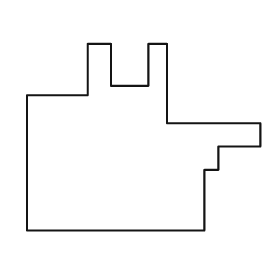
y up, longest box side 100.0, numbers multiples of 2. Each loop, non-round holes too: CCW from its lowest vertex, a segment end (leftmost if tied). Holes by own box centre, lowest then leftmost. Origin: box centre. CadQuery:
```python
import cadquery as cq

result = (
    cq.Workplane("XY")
    .moveTo(-50.0, -40.0)
    .lineTo(26.0, -40.0)
    .lineTo(26.0, -14.0)
    .lineTo(32.0, -14.0)
    .lineTo(32.0, -4.0)
    .lineTo(50.0, -4.0)
    .lineTo(50.0, 6.0)
    .lineTo(10.0, 6.0)
    .lineTo(10.0, 40.0)
    .lineTo(2.0, 40.0)
    .lineTo(2.0, 22.0)
    .lineTo(-14.0, 22.0)
    .lineTo(-14.0, 40.0)
    .lineTo(-24.0, 40.0)
    .lineTo(-24.0, 18.0)
    .lineTo(-50.0, 18.0)
    .close()
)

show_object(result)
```